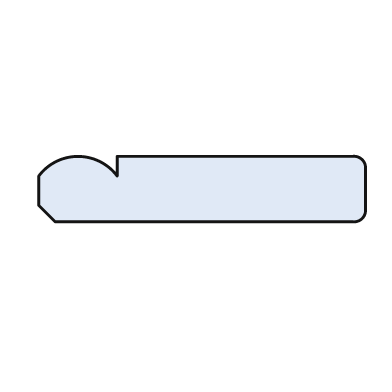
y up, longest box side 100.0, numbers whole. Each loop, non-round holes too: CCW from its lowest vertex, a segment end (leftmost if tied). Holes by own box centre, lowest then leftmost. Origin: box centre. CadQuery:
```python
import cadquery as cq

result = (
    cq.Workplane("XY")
    .moveTo(-45.0, -10.0)
    .lineTo(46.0, -10.0)
    .threePointArc((49.0, -9.0), (50.0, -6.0))
    .lineTo(50.0, 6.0)
    .threePointArc((49.0, 9.0), (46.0, 10.0))
    .lineTo(-26.0, 10.0)
    .lineTo(-26.0, 4.0)
    .threePointArc((-38.0, 10.0), (-50.0, 4.0))
    .lineTo(-50.0, -5.0)
    .close()
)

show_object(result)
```